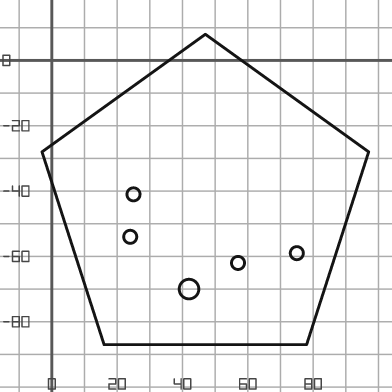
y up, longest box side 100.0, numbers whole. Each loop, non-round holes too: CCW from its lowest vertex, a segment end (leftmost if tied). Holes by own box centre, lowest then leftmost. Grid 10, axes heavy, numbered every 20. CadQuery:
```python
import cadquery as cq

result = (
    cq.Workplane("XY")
    .moveTo(16.0, -87.0)
    .lineTo(78.0, -87.0)
    .lineTo(97.0, -28.0)
    .lineTo(47.0, 8.0)
    .lineTo(-3.0, -28.0)
    .close()
    .moveTo(42.0, -70.0)
    .circle(3.0)
    .moveTo(57.0, -62.0)
    .circle(2.0)
    .moveTo(75.0, -59.0)
    .circle(2.0)
    .moveTo(24.0, -54.0)
    .circle(2.0)
    .moveTo(25.0, -41.0)
    .circle(2.0)
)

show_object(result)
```